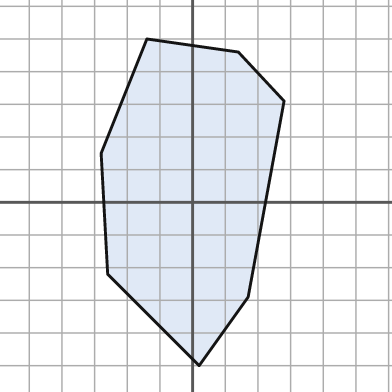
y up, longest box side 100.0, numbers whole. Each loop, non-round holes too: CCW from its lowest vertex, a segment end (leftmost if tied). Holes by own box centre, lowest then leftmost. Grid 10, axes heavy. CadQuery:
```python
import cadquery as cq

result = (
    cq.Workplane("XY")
    .moveTo(2.0, -50.0)
    .lineTo(17.0, -29.0)
    .lineTo(28.0, 31.0)
    .lineTo(14.0, 46.0)
    .lineTo(-14.0, 50.0)
    .lineTo(-28.0, 15.0)
    .lineTo(-26.0, -22.0)
    .close()
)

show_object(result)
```